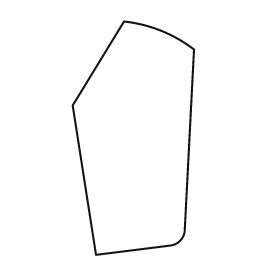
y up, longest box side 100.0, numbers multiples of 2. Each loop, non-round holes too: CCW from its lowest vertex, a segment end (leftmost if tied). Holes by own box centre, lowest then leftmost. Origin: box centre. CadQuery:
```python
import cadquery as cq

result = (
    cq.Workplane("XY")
    .moveTo(-16.0, -50.0)
    .lineTo(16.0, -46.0)
    .threePointArc((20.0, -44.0), (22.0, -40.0))
    .lineTo(26.0, 38.0)
    .threePointArc((12.0, 46.0), (-4.0, 50.0))
    .lineTo(-26.0, 14.0)
    .close()
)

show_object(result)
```